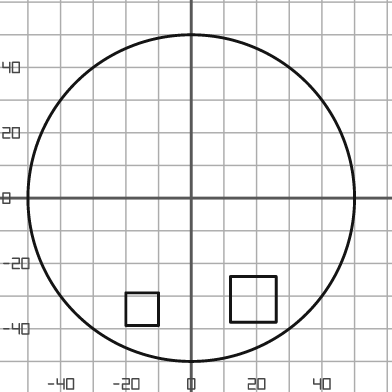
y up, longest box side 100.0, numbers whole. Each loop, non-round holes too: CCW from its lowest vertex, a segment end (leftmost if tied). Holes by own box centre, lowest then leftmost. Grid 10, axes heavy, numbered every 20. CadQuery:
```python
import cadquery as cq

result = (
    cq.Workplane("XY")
    .moveTo(0.0, 0.0)
    .circle(50.0)
    .moveTo(-20.0, -39.0)
    .lineTo(-10.0, -39.0)
    .lineTo(-10.0, -29.0)
    .lineTo(-20.0, -29.0)
    .close()
    .moveTo(12.0, -38.0)
    .lineTo(26.0, -38.0)
    .lineTo(26.0, -24.0)
    .lineTo(12.0, -24.0)
    .close()
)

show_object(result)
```